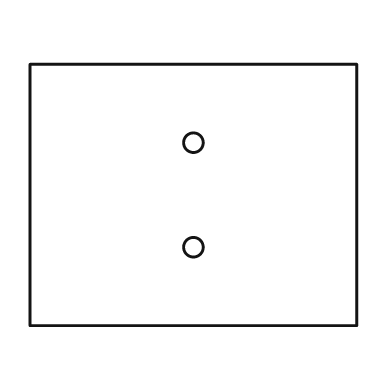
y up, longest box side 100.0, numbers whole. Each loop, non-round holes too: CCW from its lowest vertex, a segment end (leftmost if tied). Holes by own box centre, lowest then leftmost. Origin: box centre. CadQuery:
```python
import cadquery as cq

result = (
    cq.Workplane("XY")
    .moveTo(-50.0, -40.0)
    .lineTo(50.0, -40.0)
    .lineTo(50.0, 40.0)
    .lineTo(-50.0, 40.0)
    .close()
    .moveTo(0.0, -16.0)
    .circle(3.0)
    .moveTo(0.0, 16.0)
    .circle(3.0)
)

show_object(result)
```